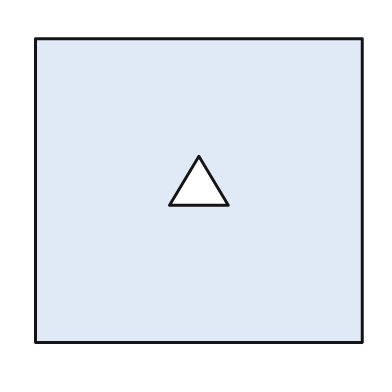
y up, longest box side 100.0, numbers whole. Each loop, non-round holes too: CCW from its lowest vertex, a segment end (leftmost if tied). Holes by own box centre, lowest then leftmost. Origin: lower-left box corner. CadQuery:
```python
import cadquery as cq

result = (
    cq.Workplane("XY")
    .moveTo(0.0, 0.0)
    .lineTo(100.0, 0.0)
    .lineTo(100.0, 93.0)
    .lineTo(0.0, 93.0)
    .close()
    .moveTo(41.0, 42.0)
    .lineTo(59.0, 42.0)
    .lineTo(50.0, 57.0)
    .close()
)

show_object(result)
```